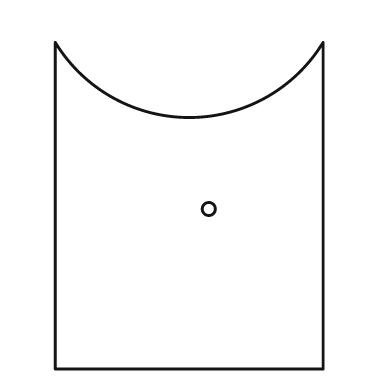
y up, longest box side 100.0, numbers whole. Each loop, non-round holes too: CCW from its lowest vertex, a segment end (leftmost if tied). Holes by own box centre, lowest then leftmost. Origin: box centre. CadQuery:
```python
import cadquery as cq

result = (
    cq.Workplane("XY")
    .moveTo(-41.0, -50.0)
    .lineTo(41.0, -50.0)
    .lineTo(41.0, 50.0)
    .threePointArc((0.0, 27.0), (-41.0, 50.0))
    .close()
    .moveTo(6.0, -1.0)
    .circle(2.0)
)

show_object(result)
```